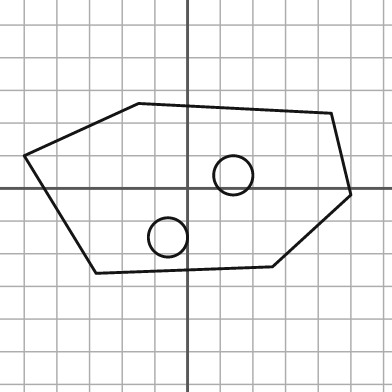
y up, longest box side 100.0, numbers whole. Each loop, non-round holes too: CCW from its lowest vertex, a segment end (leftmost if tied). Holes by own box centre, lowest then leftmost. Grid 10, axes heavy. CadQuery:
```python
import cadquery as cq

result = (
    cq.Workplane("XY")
    .moveTo(-28.0, -26.0)
    .lineTo(26.0, -24.0)
    .lineTo(50.0, -2.0)
    .lineTo(44.0, 23.0)
    .lineTo(-15.0, 26.0)
    .lineTo(-50.0, 10.0)
    .close()
    .moveTo(-6.0, -15.0)
    .circle(6.0)
    .moveTo(14.0, 4.0)
    .circle(6.0)
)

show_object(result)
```